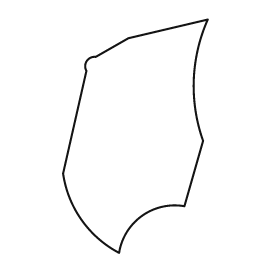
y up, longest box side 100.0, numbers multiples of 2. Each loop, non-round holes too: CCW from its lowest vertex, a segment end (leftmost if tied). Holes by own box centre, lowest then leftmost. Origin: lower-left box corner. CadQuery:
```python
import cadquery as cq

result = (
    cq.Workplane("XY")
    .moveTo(24.0, 0.0)
    .threePointArc((34.0, 16.0), (52.0, 20.0))
    .lineTo(60.0, 48.0)
    .threePointArc((56.0, 74.0), (62.0, 100.0))
    .lineTo(28.0, 92.0)
    .lineTo(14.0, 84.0)
    .threePointArc((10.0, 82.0), (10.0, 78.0))
    .lineTo(0.0, 34.0)
    .threePointArc((8.0, 14.0), (24.0, 0.0))
    .close()
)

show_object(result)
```